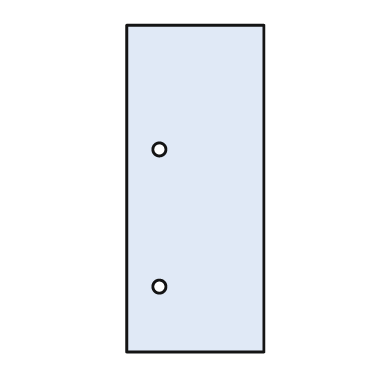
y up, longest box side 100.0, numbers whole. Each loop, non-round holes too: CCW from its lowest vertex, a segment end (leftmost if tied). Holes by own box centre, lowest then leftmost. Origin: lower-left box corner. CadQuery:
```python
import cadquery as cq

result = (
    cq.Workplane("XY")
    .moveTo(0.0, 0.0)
    .lineTo(42.0, 0.0)
    .lineTo(42.0, 100.0)
    .lineTo(0.0, 100.0)
    .close()
    .moveTo(10.0, 20.0)
    .circle(2.0)
    .moveTo(10.0, 62.0)
    .circle(2.0)
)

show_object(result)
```